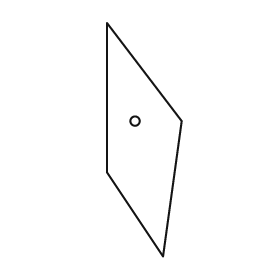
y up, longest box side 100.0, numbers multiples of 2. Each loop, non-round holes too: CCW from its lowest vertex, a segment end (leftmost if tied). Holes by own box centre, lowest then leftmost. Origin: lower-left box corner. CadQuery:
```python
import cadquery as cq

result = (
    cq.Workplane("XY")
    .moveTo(24.0, 0.0)
    .lineTo(32.0, 58.0)
    .lineTo(0.0, 100.0)
    .lineTo(0.0, 36.0)
    .close()
    .moveTo(12.0, 58.0)
    .circle(2.0)
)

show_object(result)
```